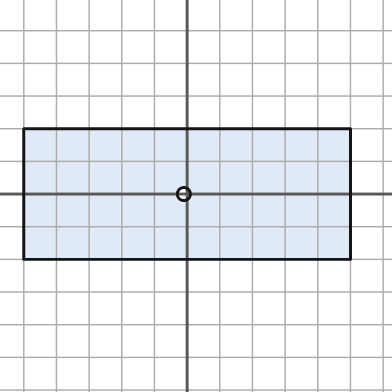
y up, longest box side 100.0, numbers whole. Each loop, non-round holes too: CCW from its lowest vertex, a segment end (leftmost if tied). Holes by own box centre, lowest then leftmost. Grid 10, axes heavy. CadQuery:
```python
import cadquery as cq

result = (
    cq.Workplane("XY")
    .moveTo(-50.0, -20.0)
    .lineTo(50.0, -20.0)
    .lineTo(50.0, 20.0)
    .lineTo(-50.0, 20.0)
    .close()
    .moveTo(-1.0, 0.0)
    .circle(2.0)
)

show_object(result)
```